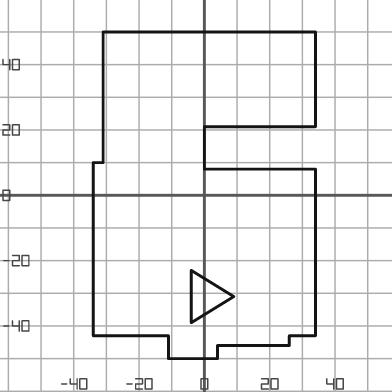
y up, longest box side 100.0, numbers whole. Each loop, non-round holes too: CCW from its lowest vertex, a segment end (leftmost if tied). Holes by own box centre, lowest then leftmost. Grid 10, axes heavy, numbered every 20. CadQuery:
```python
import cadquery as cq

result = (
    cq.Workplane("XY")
    .moveTo(-11.0, -50.0)
    .lineTo(4.0, -50.0)
    .lineTo(4.0, -46.0)
    .lineTo(26.0, -46.0)
    .lineTo(26.0, -43.0)
    .lineTo(34.0, -43.0)
    .lineTo(34.0, 8.0)
    .lineTo(0.0, 8.0)
    .lineTo(0.0, 21.0)
    .lineTo(34.0, 21.0)
    .lineTo(34.0, 50.0)
    .lineTo(-31.0, 50.0)
    .lineTo(-31.0, 10.0)
    .lineTo(-34.0, 10.0)
    .lineTo(-34.0, -43.0)
    .lineTo(-11.0, -43.0)
    .close()
    .moveTo(-4.0, -39.0)
    .lineTo(9.0, -31.0)
    .lineTo(-4.0, -23.0)
    .close()
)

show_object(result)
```